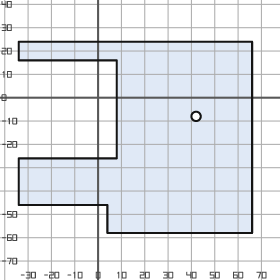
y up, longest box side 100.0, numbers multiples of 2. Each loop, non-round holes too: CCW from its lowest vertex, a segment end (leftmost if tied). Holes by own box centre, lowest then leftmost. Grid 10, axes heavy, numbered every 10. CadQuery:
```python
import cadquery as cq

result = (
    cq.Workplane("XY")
    .moveTo(4.0, -58.0)
    .lineTo(66.0, -58.0)
    .lineTo(66.0, 24.0)
    .lineTo(-34.0, 24.0)
    .lineTo(-34.0, 16.0)
    .lineTo(8.0, 16.0)
    .lineTo(8.0, -26.0)
    .lineTo(-34.0, -26.0)
    .lineTo(-34.0, -46.0)
    .lineTo(4.0, -46.0)
    .close()
    .moveTo(42.0, -8.0)
    .circle(2.0)
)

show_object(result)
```